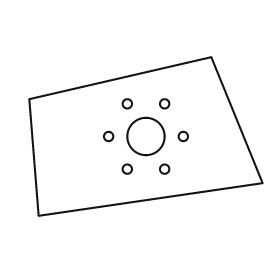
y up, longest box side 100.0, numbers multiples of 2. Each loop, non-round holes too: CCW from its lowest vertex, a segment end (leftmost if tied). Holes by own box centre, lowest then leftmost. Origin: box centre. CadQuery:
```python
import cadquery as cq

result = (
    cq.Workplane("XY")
    .moveTo(-46.0, -34.0)
    .lineTo(50.0, -20.0)
    .lineTo(28.0, 34.0)
    .lineTo(-50.0, 16.0)
    .close()
    .moveTo(-8.0, -14.0)
    .circle(2.0)
    .moveTo(8.0, -14.0)
    .circle(2.0)
    .moveTo(-16.0, 0.0)
    .circle(2.0)
    .moveTo(0.0, 0.0)
    .circle(8.0)
    .moveTo(16.0, 0.0)
    .circle(2.0)
    .moveTo(-8.0, 14.0)
    .circle(2.0)
    .moveTo(8.0, 14.0)
    .circle(2.0)
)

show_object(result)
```